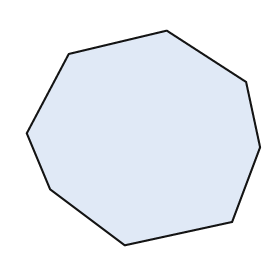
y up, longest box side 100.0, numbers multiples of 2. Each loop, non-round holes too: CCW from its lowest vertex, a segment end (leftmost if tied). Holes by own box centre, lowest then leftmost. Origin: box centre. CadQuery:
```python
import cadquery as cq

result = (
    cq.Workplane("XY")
    .moveTo(-8.0, -46.0)
    .lineTo(38.0, -36.0)
    .lineTo(50.0, -4.0)
    .lineTo(44.0, 24.0)
    .lineTo(10.0, 46.0)
    .lineTo(-32.0, 36.0)
    .lineTo(-50.0, 2.0)
    .lineTo(-40.0, -22.0)
    .close()
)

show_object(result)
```